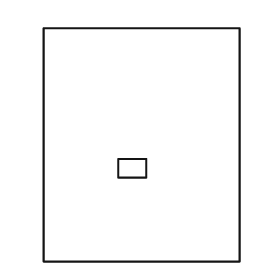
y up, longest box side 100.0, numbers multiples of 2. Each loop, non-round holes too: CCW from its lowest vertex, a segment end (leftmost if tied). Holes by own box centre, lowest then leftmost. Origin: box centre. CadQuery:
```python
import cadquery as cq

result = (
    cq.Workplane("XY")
    .moveTo(-42.0, -50.0)
    .lineTo(42.0, -50.0)
    .lineTo(42.0, 50.0)
    .lineTo(-42.0, 50.0)
    .close()
    .moveTo(-10.0, -14.0)
    .lineTo(2.0, -14.0)
    .lineTo(2.0, -6.0)
    .lineTo(-10.0, -6.0)
    .close()
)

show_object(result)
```